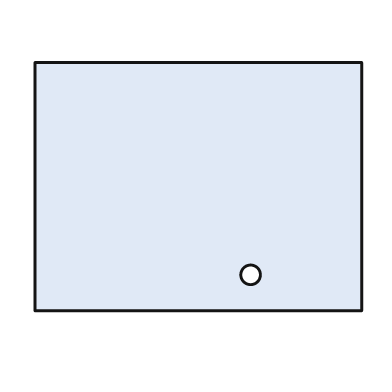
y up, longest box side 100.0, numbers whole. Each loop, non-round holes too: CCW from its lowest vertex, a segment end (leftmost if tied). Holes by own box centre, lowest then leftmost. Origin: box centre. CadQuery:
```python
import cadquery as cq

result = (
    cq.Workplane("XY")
    .moveTo(-50.0, -38.0)
    .lineTo(50.0, -38.0)
    .lineTo(50.0, 38.0)
    .lineTo(-50.0, 38.0)
    .close()
    .moveTo(16.0, -27.0)
    .circle(3.0)
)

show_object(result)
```